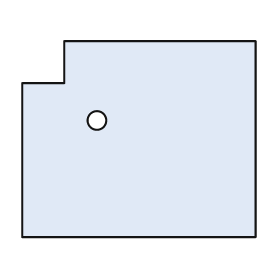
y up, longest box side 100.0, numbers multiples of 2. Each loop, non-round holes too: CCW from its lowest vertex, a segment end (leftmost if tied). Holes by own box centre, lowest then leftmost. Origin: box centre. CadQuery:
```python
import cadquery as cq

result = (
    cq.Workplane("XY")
    .moveTo(-50.0, -42.0)
    .lineTo(50.0, -42.0)
    .lineTo(50.0, 42.0)
    .lineTo(-32.0, 42.0)
    .lineTo(-32.0, 24.0)
    .lineTo(-50.0, 24.0)
    .close()
    .moveTo(-18.0, 8.0)
    .circle(4.0)
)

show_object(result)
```